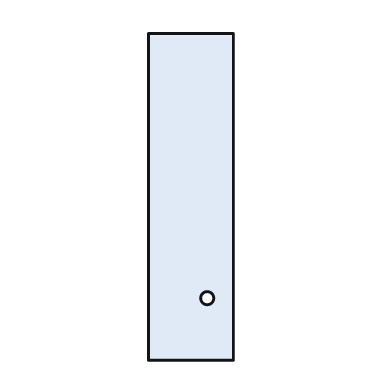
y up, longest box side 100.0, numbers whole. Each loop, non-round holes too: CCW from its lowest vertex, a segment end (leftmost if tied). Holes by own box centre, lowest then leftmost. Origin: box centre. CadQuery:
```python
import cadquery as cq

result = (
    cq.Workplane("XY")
    .moveTo(-13.0, -50.0)
    .lineTo(13.0, -50.0)
    .lineTo(13.0, 50.0)
    .lineTo(-13.0, 50.0)
    .close()
    .moveTo(5.0, -31.0)
    .circle(2.0)
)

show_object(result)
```